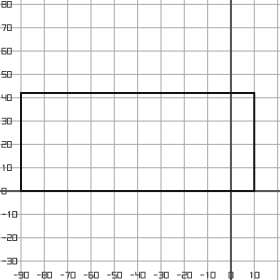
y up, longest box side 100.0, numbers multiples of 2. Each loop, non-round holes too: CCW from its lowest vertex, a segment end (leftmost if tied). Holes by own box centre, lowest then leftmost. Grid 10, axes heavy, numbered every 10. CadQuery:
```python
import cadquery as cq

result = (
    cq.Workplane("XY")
    .moveTo(-90.0, 0.0)
    .lineTo(10.0, 0.0)
    .lineTo(10.0, 42.0)
    .lineTo(-90.0, 42.0)
    .close()
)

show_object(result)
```